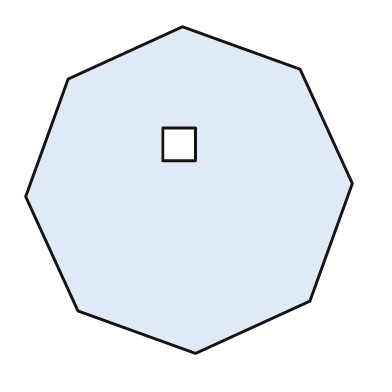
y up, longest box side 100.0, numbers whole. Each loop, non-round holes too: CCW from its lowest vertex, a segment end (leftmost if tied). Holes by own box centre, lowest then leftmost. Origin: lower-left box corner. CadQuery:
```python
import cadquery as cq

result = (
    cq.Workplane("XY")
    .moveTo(52.0, 0.0)
    .lineTo(87.0, 16.0)
    .lineTo(100.0, 52.0)
    .lineTo(84.0, 87.0)
    .lineTo(48.0, 100.0)
    .lineTo(13.0, 84.0)
    .lineTo(0.0, 48.0)
    .lineTo(16.0, 13.0)
    .close()
    .moveTo(42.0, 59.0)
    .lineTo(52.0, 59.0)
    .lineTo(52.0, 69.0)
    .lineTo(42.0, 69.0)
    .close()
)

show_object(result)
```